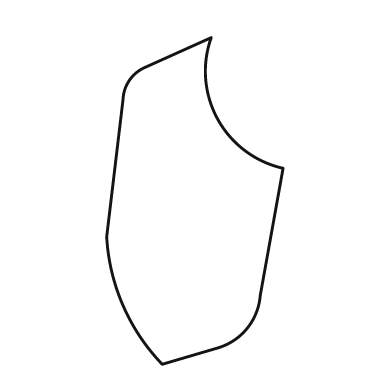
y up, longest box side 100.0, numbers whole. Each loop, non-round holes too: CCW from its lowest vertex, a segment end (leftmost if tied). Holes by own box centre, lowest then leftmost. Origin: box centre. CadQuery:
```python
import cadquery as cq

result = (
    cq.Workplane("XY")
    .moveTo(-10.0, -50.0)
    .lineTo(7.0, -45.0)
    .threePointArc((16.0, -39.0), (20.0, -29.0))
    .lineTo(27.0, 10.0)
    .threePointArc((7.0, 25.0), (5.0, 50.0))
    .lineTo(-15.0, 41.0)
    .threePointArc((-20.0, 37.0), (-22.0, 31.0))
    .lineTo(-27.0, -11.0)
    .threePointArc((-22.0, -32.0), (-10.0, -50.0))
    .close()
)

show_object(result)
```